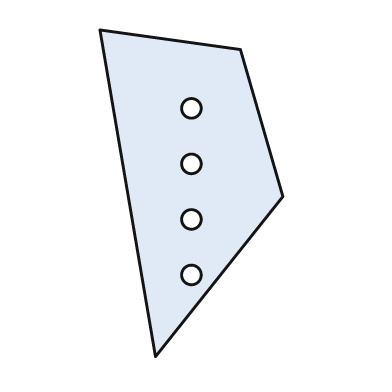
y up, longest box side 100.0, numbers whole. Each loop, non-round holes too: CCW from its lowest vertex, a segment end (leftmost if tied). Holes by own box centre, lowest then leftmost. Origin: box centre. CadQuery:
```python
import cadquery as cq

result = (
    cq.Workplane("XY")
    .moveTo(-11.0, -50.0)
    .lineTo(28.0, -1.0)
    .lineTo(15.0, 44.0)
    .lineTo(-28.0, 50.0)
    .close()
    .moveTo(0.0, -25.0)
    .circle(3.0)
    .moveTo(0.0, -8.0)
    .circle(3.0)
    .moveTo(0.0, 9.0)
    .circle(3.0)
    .moveTo(0.0, 26.0)
    .circle(3.0)
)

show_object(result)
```